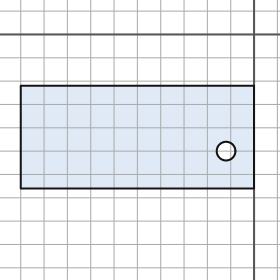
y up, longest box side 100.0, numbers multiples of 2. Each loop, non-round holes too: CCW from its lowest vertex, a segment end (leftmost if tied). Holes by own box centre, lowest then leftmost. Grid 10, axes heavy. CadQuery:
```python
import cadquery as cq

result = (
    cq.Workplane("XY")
    .moveTo(-100.0, -66.0)
    .lineTo(0.0, -66.0)
    .lineTo(0.0, -22.0)
    .lineTo(-100.0, -22.0)
    .close()
    .moveTo(-12.0, -50.0)
    .circle(4.0)
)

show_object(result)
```